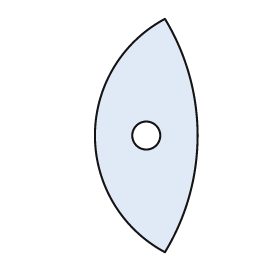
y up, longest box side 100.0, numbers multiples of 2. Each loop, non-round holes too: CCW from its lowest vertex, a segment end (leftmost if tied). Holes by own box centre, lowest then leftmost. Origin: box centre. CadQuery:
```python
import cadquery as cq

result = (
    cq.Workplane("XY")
    .moveTo(8.0, -50.0)
    .threePointArc((22.0, 0.0), (8.0, 50.0))
    .threePointArc((-22.0, 0.0), (8.0, -50.0))
    .close()
    .moveTo(0.0, 0.0)
    .circle(6.0)
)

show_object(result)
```